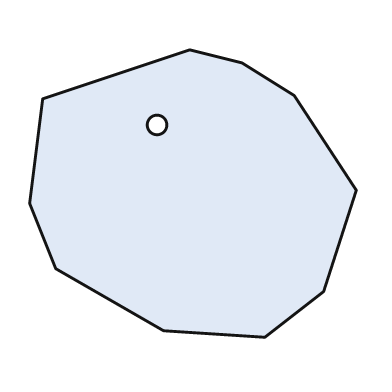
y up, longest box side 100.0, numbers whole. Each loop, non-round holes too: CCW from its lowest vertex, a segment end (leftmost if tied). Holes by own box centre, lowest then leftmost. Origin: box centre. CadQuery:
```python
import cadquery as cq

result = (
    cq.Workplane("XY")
    .moveTo(22.0, -44.0)
    .lineTo(40.0, -30.0)
    .lineTo(50.0, 1.0)
    .lineTo(31.0, 30.0)
    .lineTo(15.0, 40.0)
    .lineTo(-1.0, 44.0)
    .lineTo(-46.0, 29.0)
    .lineTo(-50.0, -3.0)
    .lineTo(-42.0, -23.0)
    .lineTo(-9.0, -42.0)
    .close()
    .moveTo(-11.0, 21.0)
    .circle(3.0)
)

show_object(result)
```